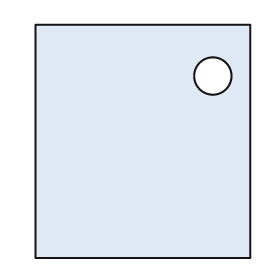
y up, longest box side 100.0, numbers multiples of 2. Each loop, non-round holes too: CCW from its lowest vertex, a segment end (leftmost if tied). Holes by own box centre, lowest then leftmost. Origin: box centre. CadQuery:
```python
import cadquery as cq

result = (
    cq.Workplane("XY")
    .moveTo(-46.0, -50.0)
    .lineTo(46.0, -50.0)
    .lineTo(46.0, 50.0)
    .lineTo(-46.0, 50.0)
    .close()
    .moveTo(30.0, 28.0)
    .circle(8.0)
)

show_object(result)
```